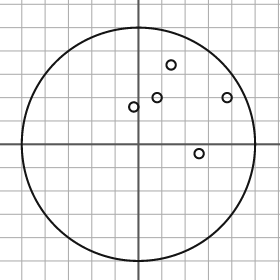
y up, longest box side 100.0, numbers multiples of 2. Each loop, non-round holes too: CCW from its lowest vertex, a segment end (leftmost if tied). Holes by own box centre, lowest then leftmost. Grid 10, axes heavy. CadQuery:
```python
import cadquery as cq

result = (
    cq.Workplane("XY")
    .moveTo(0.0, 0.0)
    .circle(50.0)
    .moveTo(26.0, -4.0)
    .circle(2.0)
    .moveTo(-2.0, 16.0)
    .circle(2.0)
    .moveTo(8.0, 20.0)
    .circle(2.0)
    .moveTo(38.0, 20.0)
    .circle(2.0)
    .moveTo(14.0, 34.0)
    .circle(2.0)
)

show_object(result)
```